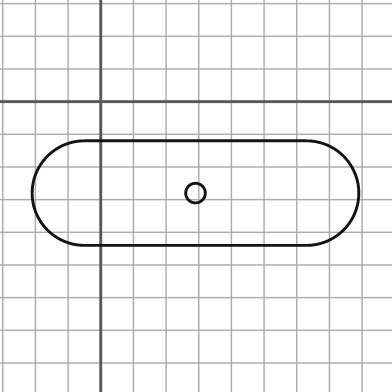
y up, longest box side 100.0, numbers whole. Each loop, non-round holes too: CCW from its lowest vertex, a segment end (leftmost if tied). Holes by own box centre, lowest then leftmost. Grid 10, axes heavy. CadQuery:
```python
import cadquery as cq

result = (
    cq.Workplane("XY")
    .moveTo(-5.0, -44.0)
    .lineTo(63.0, -44.0)
    .threePointArc((79.0, -28.0), (63.0, -12.0))
    .lineTo(-5.0, -12.0)
    .threePointArc((-21.0, -28.0), (-5.0, -44.0))
    .close()
    .moveTo(29.0, -28.0)
    .circle(3.0)
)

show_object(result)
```